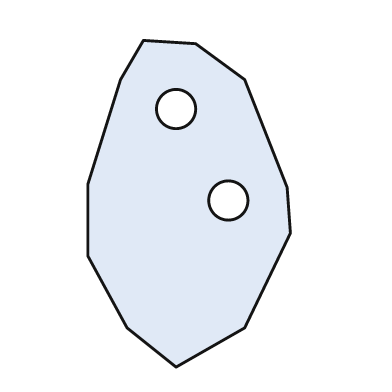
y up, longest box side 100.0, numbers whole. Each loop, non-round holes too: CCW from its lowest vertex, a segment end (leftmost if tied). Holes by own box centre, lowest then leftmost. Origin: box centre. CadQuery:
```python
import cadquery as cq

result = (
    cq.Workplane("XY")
    .moveTo(-4.0, -50.0)
    .lineTo(17.0, -38.0)
    .lineTo(31.0, -9.0)
    .lineTo(30.0, 5.0)
    .lineTo(17.0, 38.0)
    .lineTo(2.0, 49.0)
    .lineTo(-14.0, 50.0)
    .lineTo(-21.0, 38.0)
    .lineTo(-31.0, 6.0)
    .lineTo(-31.0, -16.0)
    .lineTo(-19.0, -38.0)
    .close()
    .moveTo(12.0, 1.0)
    .circle(6.0)
    .moveTo(-4.0, 29.0)
    .circle(6.0)
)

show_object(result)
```